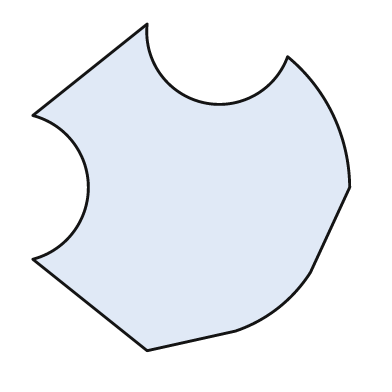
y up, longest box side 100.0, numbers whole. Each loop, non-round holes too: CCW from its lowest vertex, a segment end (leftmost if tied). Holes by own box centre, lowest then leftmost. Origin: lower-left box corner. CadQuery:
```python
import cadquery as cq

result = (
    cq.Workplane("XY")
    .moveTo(35.0, 0.0)
    .lineTo(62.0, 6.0)
    .threePointArc((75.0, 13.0), (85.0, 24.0))
    .lineTo(97.0, 50.0)
    .threePointArc((92.0, 72.0), (78.0, 90.0))
    .threePointArc((52.0, 76.0), (35.0, 100.0))
    .lineTo(0.0, 72.0)
    .threePointArc((17.0, 50.0), (0.0, 28.0))
    .close()
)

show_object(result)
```